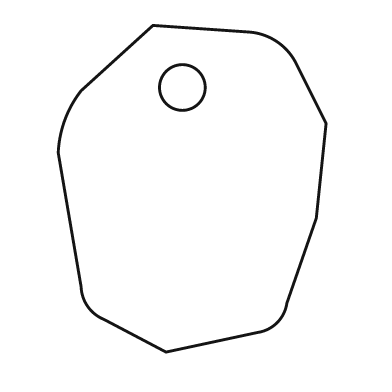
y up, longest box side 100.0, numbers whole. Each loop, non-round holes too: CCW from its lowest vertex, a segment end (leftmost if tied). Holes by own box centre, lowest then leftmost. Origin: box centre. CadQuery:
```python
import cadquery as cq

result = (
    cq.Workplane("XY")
    .moveTo(-8.0, -50.0)
    .lineTo(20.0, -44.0)
    .threePointArc((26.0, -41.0), (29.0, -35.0))
    .lineTo(38.0, -9.0)
    .lineTo(41.0, 20.0)
    .lineTo(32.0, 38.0)
    .threePointArc((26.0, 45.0), (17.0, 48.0))
    .lineTo(-12.0, 50.0)
    .lineTo(-34.0, 30.0)
    .threePointArc((-39.0, 21.0), (-41.0, 11.0))
    .lineTo(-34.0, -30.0)
    .threePointArc((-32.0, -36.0), (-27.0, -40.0))
    .close()
    .moveTo(-3.0, 31.0)
    .circle(7.0)
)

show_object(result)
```